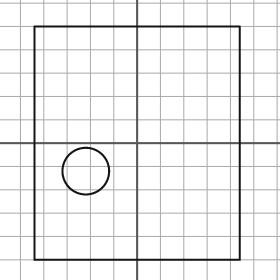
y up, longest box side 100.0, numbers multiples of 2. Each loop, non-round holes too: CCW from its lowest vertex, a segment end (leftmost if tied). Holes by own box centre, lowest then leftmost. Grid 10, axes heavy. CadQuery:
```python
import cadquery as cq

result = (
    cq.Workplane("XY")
    .moveTo(-44.0, -50.0)
    .lineTo(44.0, -50.0)
    .lineTo(44.0, 50.0)
    .lineTo(-44.0, 50.0)
    .close()
    .moveTo(-22.0, -12.0)
    .circle(10.0)
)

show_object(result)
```